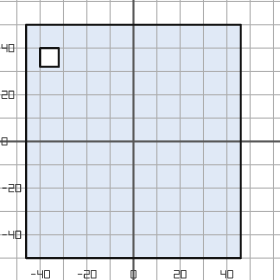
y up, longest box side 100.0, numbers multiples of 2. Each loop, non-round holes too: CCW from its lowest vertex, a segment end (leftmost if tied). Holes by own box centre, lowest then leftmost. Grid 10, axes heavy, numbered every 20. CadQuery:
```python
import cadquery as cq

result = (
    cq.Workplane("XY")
    .moveTo(-46.0, -50.0)
    .lineTo(46.0, -50.0)
    .lineTo(46.0, 50.0)
    .lineTo(-46.0, 50.0)
    .close()
    .moveTo(-40.0, 32.0)
    .lineTo(-32.0, 32.0)
    .lineTo(-32.0, 40.0)
    .lineTo(-40.0, 40.0)
    .close()
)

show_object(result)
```